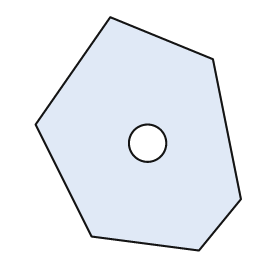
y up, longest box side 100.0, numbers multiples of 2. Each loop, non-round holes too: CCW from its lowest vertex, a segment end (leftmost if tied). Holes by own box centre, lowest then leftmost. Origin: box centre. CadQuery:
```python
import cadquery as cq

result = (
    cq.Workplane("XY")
    .moveTo(26.0, -50.0)
    .lineTo(44.0, -28.0)
    .lineTo(32.0, 32.0)
    .lineTo(-12.0, 50.0)
    .lineTo(-44.0, 4.0)
    .lineTo(-20.0, -44.0)
    .close()
    .moveTo(4.0, -4.0)
    .circle(8.0)
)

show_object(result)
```